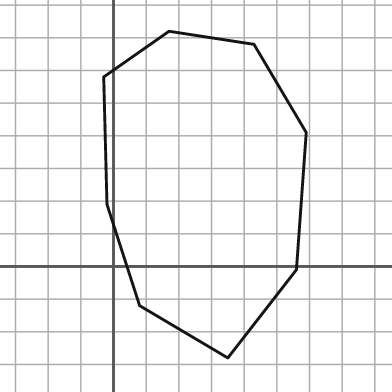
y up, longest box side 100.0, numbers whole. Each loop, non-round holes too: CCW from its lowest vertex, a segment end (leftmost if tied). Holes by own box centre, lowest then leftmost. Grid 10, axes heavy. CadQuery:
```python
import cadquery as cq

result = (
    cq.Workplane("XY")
    .moveTo(35.0, -28.0)
    .lineTo(56.0, -1.0)
    .lineTo(59.0, 41.0)
    .lineTo(43.0, 68.0)
    .lineTo(17.0, 72.0)
    .lineTo(-3.0, 58.0)
    .lineTo(-2.0, 19.0)
    .lineTo(8.0, -12.0)
    .close()
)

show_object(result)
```